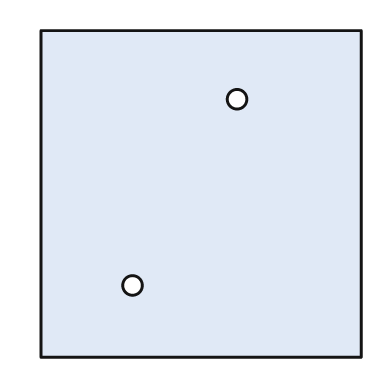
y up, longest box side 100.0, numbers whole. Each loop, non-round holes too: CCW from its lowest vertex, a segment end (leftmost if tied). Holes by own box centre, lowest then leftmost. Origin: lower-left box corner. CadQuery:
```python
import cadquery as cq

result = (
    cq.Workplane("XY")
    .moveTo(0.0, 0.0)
    .lineTo(98.0, 0.0)
    .lineTo(98.0, 100.0)
    .lineTo(0.0, 100.0)
    .close()
    .moveTo(28.0, 22.0)
    .circle(3.0)
    .moveTo(60.0, 79.0)
    .circle(3.0)
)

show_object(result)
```